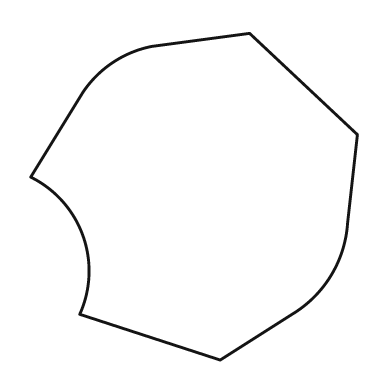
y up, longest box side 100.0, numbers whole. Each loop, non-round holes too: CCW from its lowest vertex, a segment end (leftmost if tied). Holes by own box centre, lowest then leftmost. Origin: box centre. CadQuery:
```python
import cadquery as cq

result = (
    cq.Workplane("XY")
    .moveTo(8.0, -50.0)
    .lineTo(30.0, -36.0)
    .threePointArc((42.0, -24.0), (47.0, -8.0))
    .lineTo(50.0, 19.0)
    .lineTo(17.0, 50.0)
    .lineTo(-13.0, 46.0)
    .threePointArc((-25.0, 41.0), (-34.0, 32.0))
    .lineTo(-50.0, 6.0)
    .threePointArc((-34.0, -12.0), (-35.0, -36.0))
    .close()
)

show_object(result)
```